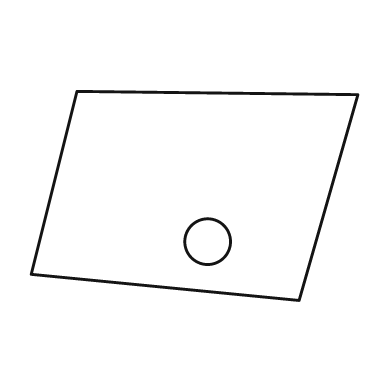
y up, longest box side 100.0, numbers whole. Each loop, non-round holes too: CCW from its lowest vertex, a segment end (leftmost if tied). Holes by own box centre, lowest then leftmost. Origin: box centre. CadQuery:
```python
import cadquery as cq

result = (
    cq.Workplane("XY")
    .moveTo(32.0, -32.0)
    .lineTo(50.0, 31.0)
    .lineTo(-36.0, 32.0)
    .lineTo(-50.0, -24.0)
    .close()
    .moveTo(4.0, -14.0)
    .circle(7.0)
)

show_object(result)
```